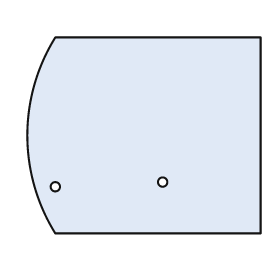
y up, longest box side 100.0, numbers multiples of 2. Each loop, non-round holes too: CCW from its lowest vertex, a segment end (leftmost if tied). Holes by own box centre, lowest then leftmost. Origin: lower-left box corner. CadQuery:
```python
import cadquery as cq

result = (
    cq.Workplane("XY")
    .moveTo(12.0, 0.0)
    .lineTo(100.0, 0.0)
    .lineTo(100.0, 84.0)
    .lineTo(12.0, 84.0)
    .threePointArc((0.0, 42.0), (12.0, 0.0))
    .close()
    .moveTo(12.0, 20.0)
    .circle(2.0)
    .moveTo(58.0, 22.0)
    .circle(2.0)
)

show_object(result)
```